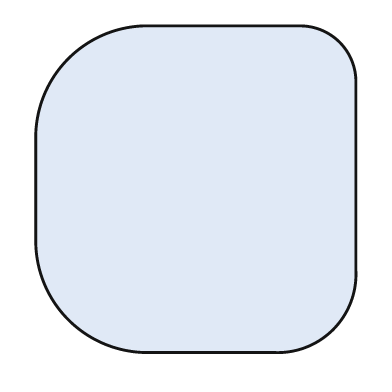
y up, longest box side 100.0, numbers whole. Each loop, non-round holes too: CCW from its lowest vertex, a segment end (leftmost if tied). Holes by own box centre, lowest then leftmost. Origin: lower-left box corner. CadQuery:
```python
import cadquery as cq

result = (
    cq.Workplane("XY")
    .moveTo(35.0, 0.0)
    .lineTo(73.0, 0.0)
    .threePointArc((91.0, 7.0), (98.0, 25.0))
    .lineTo(98.0, 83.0)
    .threePointArc((93.0, 95.0), (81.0, 100.0))
    .lineTo(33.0, 100.0)
    .threePointArc((10.0, 90.0), (0.0, 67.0))
    .lineTo(0.0, 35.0)
    .threePointArc((10.0, 10.0), (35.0, 0.0))
    .close()
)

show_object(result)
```